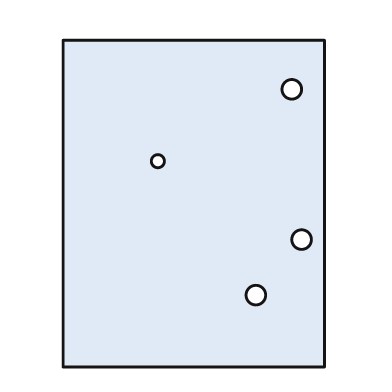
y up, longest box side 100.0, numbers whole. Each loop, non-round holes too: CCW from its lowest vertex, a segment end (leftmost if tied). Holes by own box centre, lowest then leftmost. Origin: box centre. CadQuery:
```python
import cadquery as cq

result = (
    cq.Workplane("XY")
    .moveTo(-40.0, -50.0)
    .lineTo(40.0, -50.0)
    .lineTo(40.0, 50.0)
    .lineTo(-40.0, 50.0)
    .close()
    .moveTo(19.0, -28.0)
    .circle(3.0)
    .moveTo(33.0, -11.0)
    .circle(3.0)
    .moveTo(-11.0, 13.0)
    .circle(2.0)
    .moveTo(30.0, 35.0)
    .circle(3.0)
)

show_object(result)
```